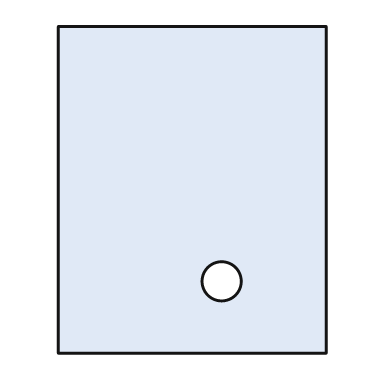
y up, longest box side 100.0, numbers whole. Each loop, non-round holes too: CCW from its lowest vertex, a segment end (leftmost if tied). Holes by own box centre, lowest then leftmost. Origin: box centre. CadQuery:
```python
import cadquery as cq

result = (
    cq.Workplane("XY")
    .moveTo(-41.0, -50.0)
    .lineTo(41.0, -50.0)
    .lineTo(41.0, 50.0)
    .lineTo(-41.0, 50.0)
    .close()
    .moveTo(9.0, -28.0)
    .circle(6.0)
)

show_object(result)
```